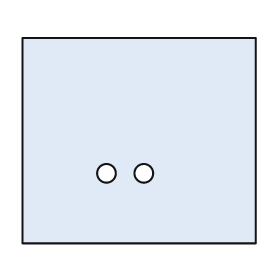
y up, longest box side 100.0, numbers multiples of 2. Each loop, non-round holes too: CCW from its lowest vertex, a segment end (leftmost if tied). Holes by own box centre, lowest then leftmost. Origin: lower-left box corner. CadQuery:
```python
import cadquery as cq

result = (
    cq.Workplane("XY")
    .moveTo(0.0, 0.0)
    .lineTo(100.0, 0.0)
    .lineTo(100.0, 88.0)
    .lineTo(0.0, 88.0)
    .close()
    .moveTo(36.0, 30.0)
    .circle(4.0)
    .moveTo(52.0, 30.0)
    .circle(4.0)
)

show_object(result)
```